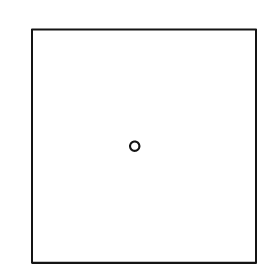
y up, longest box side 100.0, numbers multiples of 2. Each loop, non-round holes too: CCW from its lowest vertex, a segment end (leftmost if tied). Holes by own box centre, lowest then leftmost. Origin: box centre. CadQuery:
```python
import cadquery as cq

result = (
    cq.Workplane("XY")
    .moveTo(-48.0, -50.0)
    .lineTo(48.0, -50.0)
    .lineTo(48.0, 50.0)
    .lineTo(-48.0, 50.0)
    .close()
    .moveTo(-4.0, 0.0)
    .circle(2.0)
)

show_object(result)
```